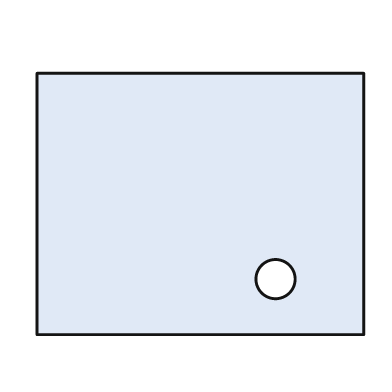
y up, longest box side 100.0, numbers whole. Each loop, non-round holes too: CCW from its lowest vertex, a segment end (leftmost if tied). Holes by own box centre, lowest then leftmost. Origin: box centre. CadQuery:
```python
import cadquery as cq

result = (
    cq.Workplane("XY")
    .moveTo(-50.0, -40.0)
    .lineTo(50.0, -40.0)
    .lineTo(50.0, 40.0)
    .lineTo(-50.0, 40.0)
    .close()
    .moveTo(23.0, -23.0)
    .circle(6.0)
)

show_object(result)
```